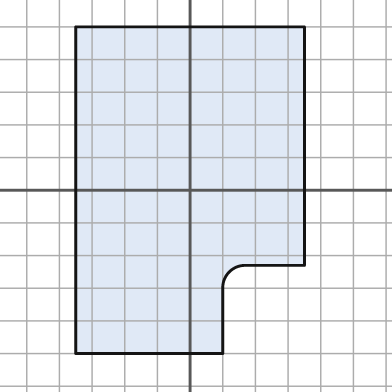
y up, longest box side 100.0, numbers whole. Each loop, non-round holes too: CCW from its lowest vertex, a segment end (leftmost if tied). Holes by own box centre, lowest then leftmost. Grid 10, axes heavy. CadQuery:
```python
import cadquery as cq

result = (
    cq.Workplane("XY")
    .moveTo(-35.0, -50.0)
    .lineTo(10.0, -50.0)
    .lineTo(10.0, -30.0)
    .threePointArc((12.0, -25.0), (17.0, -23.0))
    .lineTo(35.0, -23.0)
    .lineTo(35.0, 50.0)
    .lineTo(-35.0, 50.0)
    .close()
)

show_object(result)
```